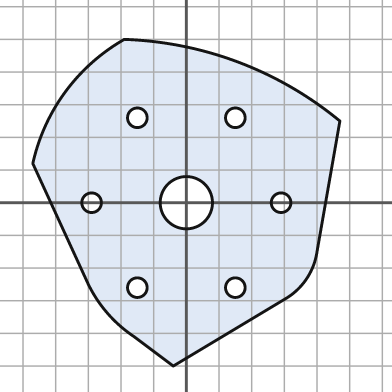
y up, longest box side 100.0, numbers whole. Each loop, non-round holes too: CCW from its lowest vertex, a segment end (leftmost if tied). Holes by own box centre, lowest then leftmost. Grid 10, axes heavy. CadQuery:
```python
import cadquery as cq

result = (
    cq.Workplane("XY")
    .moveTo(-4.0, -50.0)
    .lineTo(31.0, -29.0)
    .threePointArc((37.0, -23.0), (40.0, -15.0))
    .lineTo(47.0, 25.0)
    .threePointArc((16.0, 43.0), (-19.0, 50.0))
    .threePointArc((-37.0, 34.0), (-47.0, 12.0))
    .lineTo(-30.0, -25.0)
    .threePointArc((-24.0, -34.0), (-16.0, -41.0))
    .close()
    .moveTo(-15.0, -26.0)
    .circle(3.0)
    .moveTo(15.0, -26.0)
    .circle(3.0)
    .moveTo(-29.0, 0.0)
    .circle(3.0)
    .moveTo(0.0, 0.0)
    .circle(8.0)
    .moveTo(29.0, 0.0)
    .circle(3.0)
    .moveTo(-15.0, 26.0)
    .circle(3.0)
    .moveTo(15.0, 26.0)
    .circle(3.0)
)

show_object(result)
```